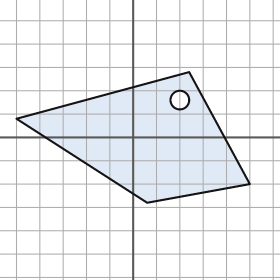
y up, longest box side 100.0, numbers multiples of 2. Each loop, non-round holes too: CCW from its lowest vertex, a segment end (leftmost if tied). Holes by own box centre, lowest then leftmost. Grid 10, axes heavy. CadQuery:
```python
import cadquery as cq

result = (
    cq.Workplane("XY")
    .moveTo(6.0, -28.0)
    .lineTo(50.0, -20.0)
    .lineTo(24.0, 28.0)
    .lineTo(-50.0, 8.0)
    .close()
    .moveTo(20.0, 16.0)
    .circle(4.0)
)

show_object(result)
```